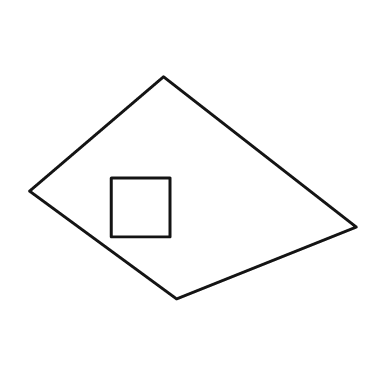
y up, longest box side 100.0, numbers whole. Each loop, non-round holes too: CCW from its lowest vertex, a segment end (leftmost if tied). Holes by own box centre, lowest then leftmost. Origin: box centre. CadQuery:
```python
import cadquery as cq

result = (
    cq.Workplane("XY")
    .moveTo(-5.0, -34.0)
    .lineTo(50.0, -12.0)
    .lineTo(-9.0, 34.0)
    .lineTo(-50.0, -1.0)
    .close()
    .moveTo(-25.0, -15.0)
    .lineTo(-7.0, -15.0)
    .lineTo(-7.0, 3.0)
    .lineTo(-25.0, 3.0)
    .close()
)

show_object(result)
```